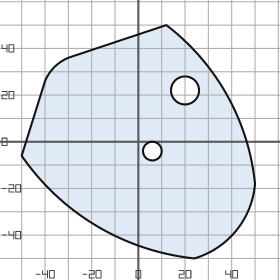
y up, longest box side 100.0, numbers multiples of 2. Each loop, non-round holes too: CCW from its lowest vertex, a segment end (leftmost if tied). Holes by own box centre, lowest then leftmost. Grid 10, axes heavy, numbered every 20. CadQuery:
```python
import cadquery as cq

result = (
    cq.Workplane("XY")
    .moveTo(24.0, -50.0)
    .threePointArc((42.0, -38.0), (50.0, -18.0))
    .threePointArc((38.0, 20.0), (12.0, 50.0))
    .lineTo(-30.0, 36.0)
    .threePointArc((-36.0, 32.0), (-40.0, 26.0))
    .lineTo(-50.0, -6.0)
    .threePointArc((-18.0, -36.0), (24.0, -50.0))
    .close()
    .moveTo(6.0, -4.0)
    .circle(4.0)
    .moveTo(20.0, 22.0)
    .circle(6.0)
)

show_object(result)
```